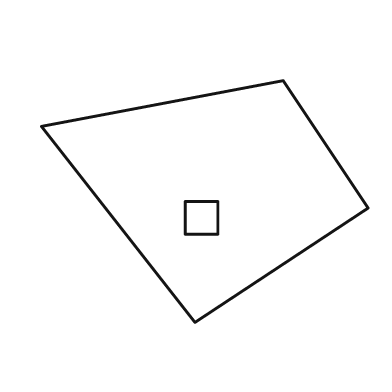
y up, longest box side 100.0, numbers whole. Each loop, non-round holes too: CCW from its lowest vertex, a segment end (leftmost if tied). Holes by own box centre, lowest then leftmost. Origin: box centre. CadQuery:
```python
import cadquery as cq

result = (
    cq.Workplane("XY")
    .moveTo(-3.0, -37.0)
    .lineTo(50.0, -2.0)
    .lineTo(24.0, 37.0)
    .lineTo(-50.0, 23.0)
    .close()
    .moveTo(-6.0, -10.0)
    .lineTo(4.0, -10.0)
    .lineTo(4.0, 0.0)
    .lineTo(-6.0, 0.0)
    .close()
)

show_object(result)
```